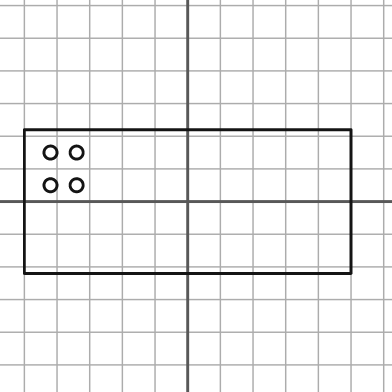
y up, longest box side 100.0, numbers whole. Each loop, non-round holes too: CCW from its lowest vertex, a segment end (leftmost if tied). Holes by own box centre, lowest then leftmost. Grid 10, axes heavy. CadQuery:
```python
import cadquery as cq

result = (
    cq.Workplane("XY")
    .moveTo(-50.0, -22.0)
    .lineTo(50.0, -22.0)
    .lineTo(50.0, 22.0)
    .lineTo(-50.0, 22.0)
    .close()
    .moveTo(-42.0, 5.0)
    .circle(2.0)
    .moveTo(-34.0, 5.0)
    .circle(2.0)
    .moveTo(-42.0, 15.0)
    .circle(2.0)
    .moveTo(-34.0, 15.0)
    .circle(2.0)
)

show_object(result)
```